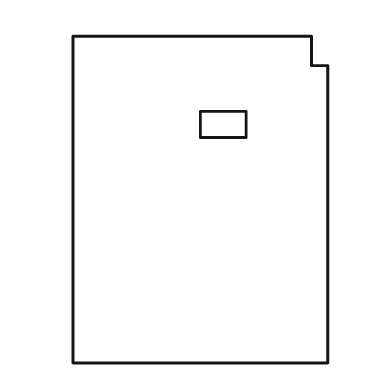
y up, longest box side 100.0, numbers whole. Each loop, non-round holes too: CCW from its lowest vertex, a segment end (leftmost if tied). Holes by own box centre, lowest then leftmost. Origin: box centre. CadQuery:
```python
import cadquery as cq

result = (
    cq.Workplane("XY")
    .moveTo(-39.0, -50.0)
    .lineTo(39.0, -50.0)
    .lineTo(39.0, 41.0)
    .lineTo(34.0, 41.0)
    .lineTo(34.0, 50.0)
    .lineTo(-39.0, 50.0)
    .close()
    .moveTo(0.0, 19.0)
    .lineTo(14.0, 19.0)
    .lineTo(14.0, 27.0)
    .lineTo(0.0, 27.0)
    .close()
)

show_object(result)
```